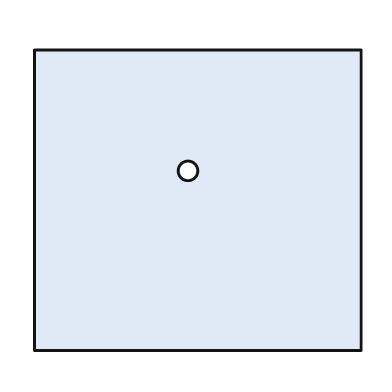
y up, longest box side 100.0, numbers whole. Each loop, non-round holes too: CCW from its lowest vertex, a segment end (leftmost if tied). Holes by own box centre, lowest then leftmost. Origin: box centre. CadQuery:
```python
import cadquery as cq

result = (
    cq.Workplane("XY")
    .moveTo(-50.0, -46.0)
    .lineTo(50.0, -46.0)
    .lineTo(50.0, 46.0)
    .lineTo(-50.0, 46.0)
    .close()
    .moveTo(-3.0, 9.0)
    .circle(3.0)
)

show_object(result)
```